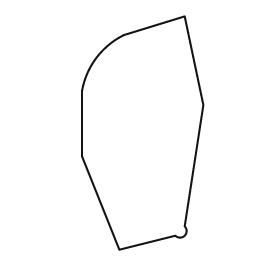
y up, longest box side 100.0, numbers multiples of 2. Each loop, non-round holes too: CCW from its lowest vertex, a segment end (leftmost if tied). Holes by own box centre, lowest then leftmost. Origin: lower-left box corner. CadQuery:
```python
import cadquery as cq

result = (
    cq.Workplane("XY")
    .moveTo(16.0, 0.0)
    .lineTo(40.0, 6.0)
    .threePointArc((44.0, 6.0), (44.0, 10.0))
    .lineTo(52.0, 62.0)
    .lineTo(44.0, 100.0)
    .lineTo(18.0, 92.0)
    .threePointArc((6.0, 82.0), (0.0, 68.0))
    .lineTo(0.0, 40.0)
    .close()
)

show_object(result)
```